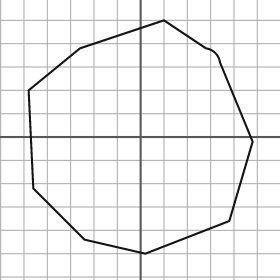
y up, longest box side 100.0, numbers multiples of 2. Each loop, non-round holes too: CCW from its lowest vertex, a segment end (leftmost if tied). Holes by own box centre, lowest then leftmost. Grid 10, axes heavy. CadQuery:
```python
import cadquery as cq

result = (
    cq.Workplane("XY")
    .moveTo(2.0, -50.0)
    .lineTo(38.0, -36.0)
    .lineTo(48.0, -2.0)
    .lineTo(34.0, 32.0)
    .threePointArc((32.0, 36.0), (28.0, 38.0))
    .lineTo(10.0, 50.0)
    .lineTo(-26.0, 38.0)
    .lineTo(-48.0, 20.0)
    .lineTo(-46.0, -22.0)
    .lineTo(-24.0, -44.0)
    .close()
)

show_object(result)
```